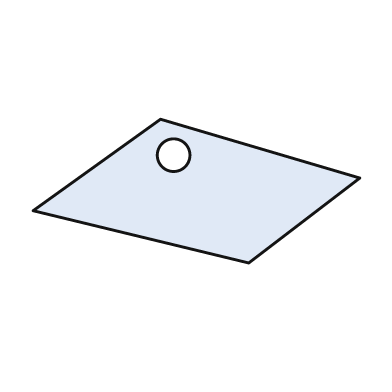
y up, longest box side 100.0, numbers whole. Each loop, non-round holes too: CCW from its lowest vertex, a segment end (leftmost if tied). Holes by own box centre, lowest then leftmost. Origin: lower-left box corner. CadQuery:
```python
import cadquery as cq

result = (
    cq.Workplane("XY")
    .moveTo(66.0, 0.0)
    .lineTo(100.0, 26.0)
    .lineTo(39.0, 44.0)
    .lineTo(0.0, 16.0)
    .close()
    .moveTo(43.0, 33.0)
    .circle(5.0)
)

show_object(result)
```